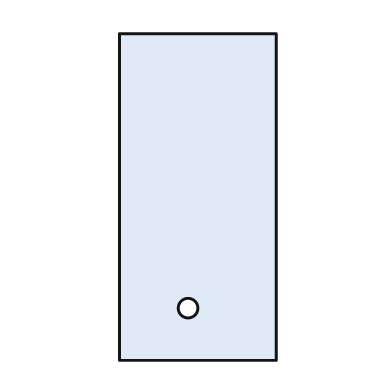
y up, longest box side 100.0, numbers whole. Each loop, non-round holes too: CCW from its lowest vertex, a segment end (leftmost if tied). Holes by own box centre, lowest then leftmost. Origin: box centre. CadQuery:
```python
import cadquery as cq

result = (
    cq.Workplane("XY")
    .moveTo(-24.0, -50.0)
    .lineTo(24.0, -50.0)
    .lineTo(24.0, 50.0)
    .lineTo(-24.0, 50.0)
    .close()
    .moveTo(-3.0, -34.0)
    .circle(3.0)
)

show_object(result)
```